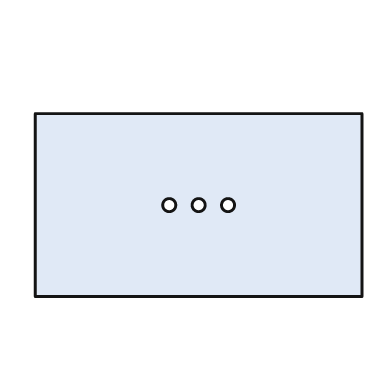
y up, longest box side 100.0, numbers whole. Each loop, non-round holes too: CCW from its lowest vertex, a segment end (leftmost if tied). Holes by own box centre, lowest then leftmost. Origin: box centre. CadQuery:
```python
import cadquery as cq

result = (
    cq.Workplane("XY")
    .moveTo(-50.0, -28.0)
    .lineTo(50.0, -28.0)
    .lineTo(50.0, 28.0)
    .lineTo(-50.0, 28.0)
    .close()
    .moveTo(-9.0, 0.0)
    .circle(2.0)
    .moveTo(0.0, 0.0)
    .circle(2.0)
    .moveTo(9.0, 0.0)
    .circle(2.0)
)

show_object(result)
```